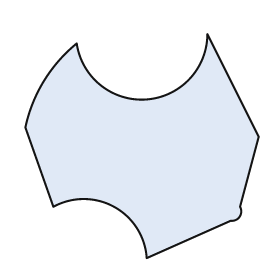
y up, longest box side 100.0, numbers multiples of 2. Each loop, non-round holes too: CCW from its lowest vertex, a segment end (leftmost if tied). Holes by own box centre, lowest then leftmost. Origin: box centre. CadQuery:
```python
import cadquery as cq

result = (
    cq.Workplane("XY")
    .moveTo(2.0, -48.0)
    .lineTo(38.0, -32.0)
    .threePointArc((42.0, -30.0), (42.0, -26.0))
    .lineTo(50.0, 4.0)
    .lineTo(28.0, 48.0)
    .threePointArc((2.0, 20.0), (-28.0, 44.0))
    .threePointArc((-42.0, 28.0), (-50.0, 8.0))
    .lineTo(-38.0, -26.0)
    .threePointArc((-12.0, -26.0), (2.0, -48.0))
    .close()
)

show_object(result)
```